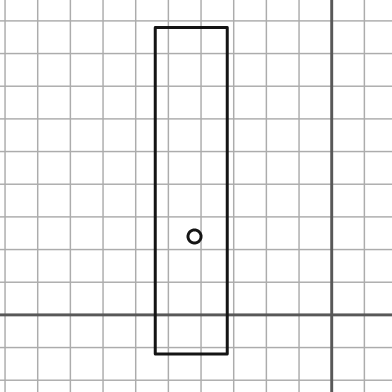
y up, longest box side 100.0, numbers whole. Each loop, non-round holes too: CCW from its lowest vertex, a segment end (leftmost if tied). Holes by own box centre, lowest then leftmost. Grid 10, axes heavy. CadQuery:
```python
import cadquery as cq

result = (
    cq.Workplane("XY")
    .moveTo(-54.0, -12.0)
    .lineTo(-32.0, -12.0)
    .lineTo(-32.0, 88.0)
    .lineTo(-54.0, 88.0)
    .close()
    .moveTo(-42.0, 24.0)
    .circle(2.0)
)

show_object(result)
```